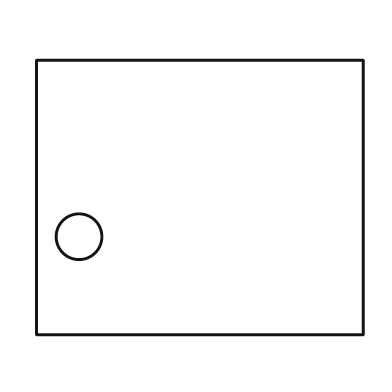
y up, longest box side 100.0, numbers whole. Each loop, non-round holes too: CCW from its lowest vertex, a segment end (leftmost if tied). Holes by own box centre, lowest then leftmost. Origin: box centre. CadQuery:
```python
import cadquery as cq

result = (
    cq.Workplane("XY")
    .moveTo(-50.0, -42.0)
    .lineTo(50.0, -42.0)
    .lineTo(50.0, 42.0)
    .lineTo(-50.0, 42.0)
    .close()
    .moveTo(-37.0, -12.0)
    .circle(7.0)
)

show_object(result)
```